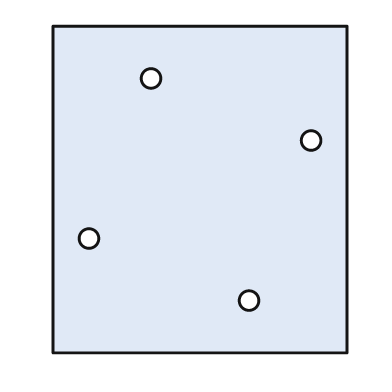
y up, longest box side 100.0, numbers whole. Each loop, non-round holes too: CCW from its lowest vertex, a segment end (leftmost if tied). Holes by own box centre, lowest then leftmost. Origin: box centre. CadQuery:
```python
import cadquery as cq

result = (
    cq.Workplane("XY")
    .moveTo(-45.0, -50.0)
    .lineTo(45.0, -50.0)
    .lineTo(45.0, 50.0)
    .lineTo(-45.0, 50.0)
    .close()
    .moveTo(15.0, -34.0)
    .circle(3.0)
    .moveTo(-34.0, -15.0)
    .circle(3.0)
    .moveTo(34.0, 15.0)
    .circle(3.0)
    .moveTo(-15.0, 34.0)
    .circle(3.0)
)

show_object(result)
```